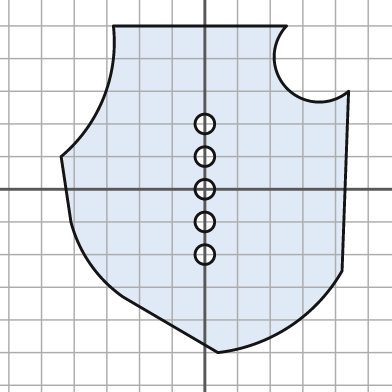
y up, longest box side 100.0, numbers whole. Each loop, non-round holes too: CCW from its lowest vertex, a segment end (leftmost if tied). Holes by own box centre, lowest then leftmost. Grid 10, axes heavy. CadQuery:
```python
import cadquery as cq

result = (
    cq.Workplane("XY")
    .moveTo(4.0, -50.0)
    .threePointArc((26.0, -42.0), (42.0, -25.0))
    .lineTo(44.0, 30.0)
    .threePointArc((25.0, 31.0), (25.0, 50.0))
    .lineTo(-28.0, 50.0)
    .threePointArc((-31.0, 28.0), (-44.0, 10.0))
    .lineTo(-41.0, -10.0)
    .threePointArc((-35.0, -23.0), (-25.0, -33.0))
    .close()
    .moveTo(0.0, -20.0)
    .circle(3.0)
    .moveTo(0.0, -10.0)
    .circle(3.0)
    .moveTo(0.0, 0.0)
    .circle(3.0)
    .moveTo(0.0, 10.0)
    .circle(3.0)
    .moveTo(0.0, 20.0)
    .circle(3.0)
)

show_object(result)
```